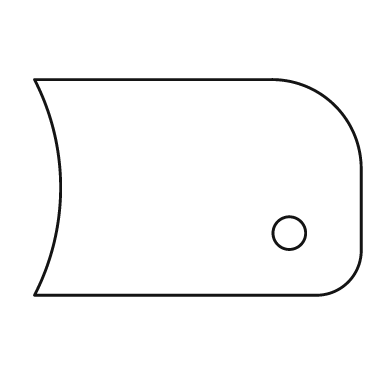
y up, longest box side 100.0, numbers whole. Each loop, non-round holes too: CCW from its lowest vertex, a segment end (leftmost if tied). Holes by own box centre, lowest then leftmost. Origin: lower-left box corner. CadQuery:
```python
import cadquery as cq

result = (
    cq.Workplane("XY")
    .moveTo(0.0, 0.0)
    .lineTo(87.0, 0.0)
    .threePointArc((96.0, 4.0), (100.0, 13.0))
    .lineTo(100.0, 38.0)
    .threePointArc((92.0, 58.0), (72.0, 66.0))
    .lineTo(0.0, 66.0)
    .threePointArc((8.0, 33.0), (0.0, 0.0))
    .close()
    .moveTo(78.0, 19.0)
    .circle(5.0)
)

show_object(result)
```